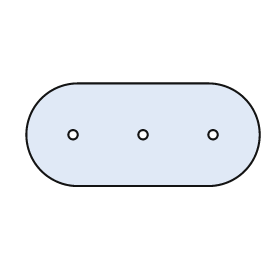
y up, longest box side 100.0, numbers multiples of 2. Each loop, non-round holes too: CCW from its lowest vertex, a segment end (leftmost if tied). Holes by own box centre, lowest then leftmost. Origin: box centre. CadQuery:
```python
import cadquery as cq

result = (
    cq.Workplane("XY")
    .moveTo(-28.0, -22.0)
    .lineTo(28.0, -22.0)
    .threePointArc((50.0, 0.0), (28.0, 22.0))
    .lineTo(-28.0, 22.0)
    .threePointArc((-50.0, 0.0), (-28.0, -22.0))
    .close()
    .moveTo(-30.0, 0.0)
    .circle(2.0)
    .moveTo(0.0, 0.0)
    .circle(2.0)
    .moveTo(30.0, 0.0)
    .circle(2.0)
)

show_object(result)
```